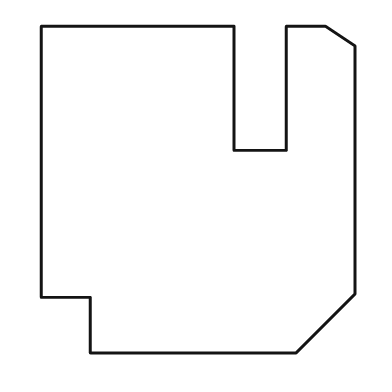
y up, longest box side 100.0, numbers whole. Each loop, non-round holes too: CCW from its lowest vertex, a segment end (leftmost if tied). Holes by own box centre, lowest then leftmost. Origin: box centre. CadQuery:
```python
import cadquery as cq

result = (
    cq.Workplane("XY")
    .moveTo(-33.0, -50.0)
    .lineTo(30.0, -50.0)
    .lineTo(48.0, -32.0)
    .lineTo(48.0, 44.0)
    .lineTo(39.0, 50.0)
    .lineTo(27.0, 50.0)
    .lineTo(27.0, 12.0)
    .lineTo(11.0, 12.0)
    .lineTo(11.0, 50.0)
    .lineTo(-48.0, 50.0)
    .lineTo(-48.0, -33.0)
    .lineTo(-33.0, -33.0)
    .close()
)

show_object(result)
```